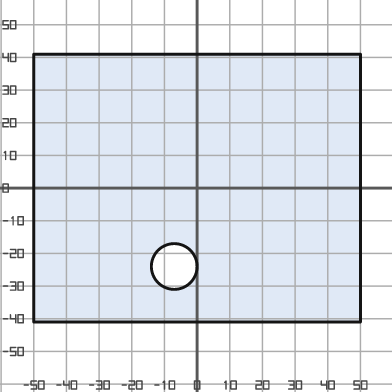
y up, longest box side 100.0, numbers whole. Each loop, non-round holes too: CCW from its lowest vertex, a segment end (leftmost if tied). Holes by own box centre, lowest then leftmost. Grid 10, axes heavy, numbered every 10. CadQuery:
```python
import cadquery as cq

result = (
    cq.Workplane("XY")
    .moveTo(-50.0, -41.0)
    .lineTo(50.0, -41.0)
    .lineTo(50.0, 41.0)
    .lineTo(-50.0, 41.0)
    .close()
    .moveTo(-7.0, -24.0)
    .circle(7.0)
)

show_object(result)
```